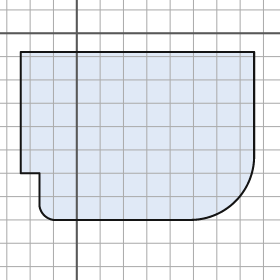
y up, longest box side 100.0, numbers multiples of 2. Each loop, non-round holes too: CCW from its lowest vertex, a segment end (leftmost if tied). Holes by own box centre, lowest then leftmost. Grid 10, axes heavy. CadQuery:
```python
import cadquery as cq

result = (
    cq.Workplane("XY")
    .moveTo(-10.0, -80.0)
    .lineTo(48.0, -80.0)
    .threePointArc((68.0, -72.0), (76.0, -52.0))
    .lineTo(76.0, -8.0)
    .lineTo(-24.0, -8.0)
    .lineTo(-24.0, -60.0)
    .lineTo(-16.0, -60.0)
    .lineTo(-16.0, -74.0)
    .threePointArc((-14.0, -78.0), (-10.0, -80.0))
    .close()
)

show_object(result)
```